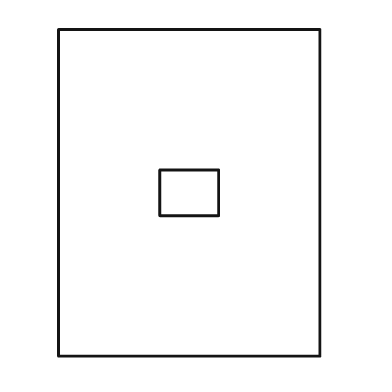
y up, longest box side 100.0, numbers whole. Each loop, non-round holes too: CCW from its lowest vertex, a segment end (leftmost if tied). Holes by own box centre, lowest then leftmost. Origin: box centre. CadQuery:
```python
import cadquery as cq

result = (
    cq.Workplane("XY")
    .moveTo(-40.0, -50.0)
    .lineTo(40.0, -50.0)
    .lineTo(40.0, 50.0)
    .lineTo(-40.0, 50.0)
    .close()
    .moveTo(-9.0, -7.0)
    .lineTo(9.0, -7.0)
    .lineTo(9.0, 7.0)
    .lineTo(-9.0, 7.0)
    .close()
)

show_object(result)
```